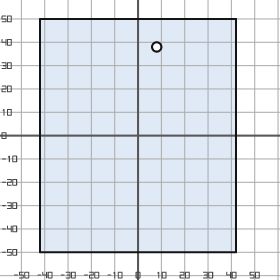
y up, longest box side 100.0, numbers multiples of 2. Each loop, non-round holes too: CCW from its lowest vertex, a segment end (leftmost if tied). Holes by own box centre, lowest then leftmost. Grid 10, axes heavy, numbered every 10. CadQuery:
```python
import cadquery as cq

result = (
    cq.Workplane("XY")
    .moveTo(-42.0, -50.0)
    .lineTo(42.0, -50.0)
    .lineTo(42.0, 50.0)
    .lineTo(-42.0, 50.0)
    .close()
    .moveTo(8.0, 38.0)
    .circle(2.0)
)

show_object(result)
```